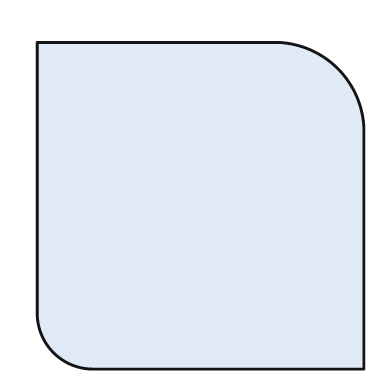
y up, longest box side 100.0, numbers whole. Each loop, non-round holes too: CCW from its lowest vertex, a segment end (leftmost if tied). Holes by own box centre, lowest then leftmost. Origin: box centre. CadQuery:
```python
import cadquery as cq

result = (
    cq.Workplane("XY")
    .moveTo(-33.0, -50.0)
    .lineTo(50.0, -50.0)
    .lineTo(50.0, 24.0)
    .threePointArc((42.0, 42.0), (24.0, 50.0))
    .lineTo(-50.0, 50.0)
    .lineTo(-50.0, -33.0)
    .threePointArc((-45.0, -45.0), (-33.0, -50.0))
    .close()
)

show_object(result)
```